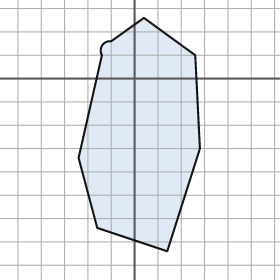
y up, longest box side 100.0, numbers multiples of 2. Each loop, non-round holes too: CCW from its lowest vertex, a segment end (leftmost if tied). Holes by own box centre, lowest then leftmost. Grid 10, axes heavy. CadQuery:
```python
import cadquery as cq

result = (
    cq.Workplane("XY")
    .moveTo(14.0, -74.0)
    .lineTo(28.0, -30.0)
    .lineTo(26.0, 10.0)
    .lineTo(4.0, 26.0)
    .lineTo(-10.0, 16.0)
    .threePointArc((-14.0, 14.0), (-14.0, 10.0))
    .lineTo(-24.0, -34.0)
    .lineTo(-16.0, -64.0)
    .close()
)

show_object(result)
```